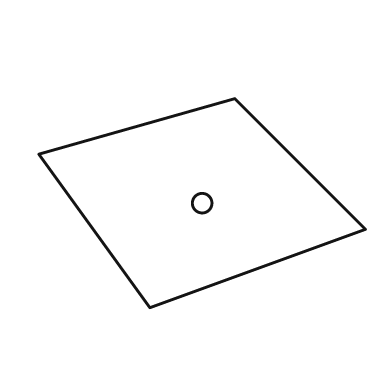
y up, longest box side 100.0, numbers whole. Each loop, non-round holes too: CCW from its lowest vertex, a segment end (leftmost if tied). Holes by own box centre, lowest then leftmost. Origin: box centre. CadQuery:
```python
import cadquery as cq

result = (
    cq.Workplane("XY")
    .moveTo(-16.0, -32.0)
    .lineTo(50.0, -8.0)
    .lineTo(10.0, 32.0)
    .lineTo(-50.0, 15.0)
    .close()
    .moveTo(0.0, 0.0)
    .circle(3.0)
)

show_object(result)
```